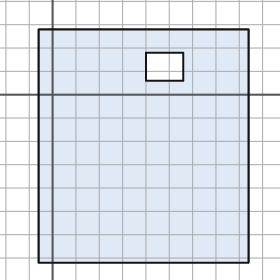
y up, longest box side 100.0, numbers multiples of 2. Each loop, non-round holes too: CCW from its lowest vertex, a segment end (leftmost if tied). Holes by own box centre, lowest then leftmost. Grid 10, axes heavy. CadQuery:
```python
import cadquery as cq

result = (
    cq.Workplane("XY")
    .moveTo(-6.0, -72.0)
    .lineTo(84.0, -72.0)
    .lineTo(84.0, 28.0)
    .lineTo(-6.0, 28.0)
    .close()
    .moveTo(40.0, 6.0)
    .lineTo(56.0, 6.0)
    .lineTo(56.0, 18.0)
    .lineTo(40.0, 18.0)
    .close()
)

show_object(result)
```